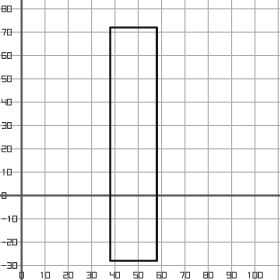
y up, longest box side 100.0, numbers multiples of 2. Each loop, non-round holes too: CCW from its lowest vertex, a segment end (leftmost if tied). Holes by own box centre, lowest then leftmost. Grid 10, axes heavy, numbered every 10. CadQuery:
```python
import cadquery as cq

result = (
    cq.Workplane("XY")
    .moveTo(38.0, -28.0)
    .lineTo(58.0, -28.0)
    .lineTo(58.0, 72.0)
    .lineTo(38.0, 72.0)
    .close()
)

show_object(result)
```